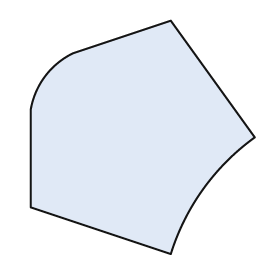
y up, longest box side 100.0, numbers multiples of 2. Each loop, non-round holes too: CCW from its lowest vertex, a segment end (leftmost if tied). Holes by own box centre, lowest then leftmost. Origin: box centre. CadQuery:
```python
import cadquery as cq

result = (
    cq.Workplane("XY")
    .moveTo(12.0, -50.0)
    .threePointArc((26.0, -22.0), (48.0, 0.0))
    .lineTo(12.0, 50.0)
    .lineTo(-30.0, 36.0)
    .threePointArc((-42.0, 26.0), (-48.0, 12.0))
    .lineTo(-48.0, -30.0)
    .close()
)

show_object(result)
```